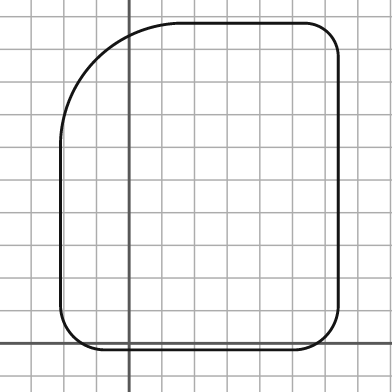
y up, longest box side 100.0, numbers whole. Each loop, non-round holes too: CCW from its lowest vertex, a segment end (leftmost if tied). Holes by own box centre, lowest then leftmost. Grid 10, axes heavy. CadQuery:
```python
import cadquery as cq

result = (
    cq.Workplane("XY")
    .moveTo(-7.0, -2.0)
    .lineTo(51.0, -2.0)
    .threePointArc((60.0, 2.0), (64.0, 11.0))
    .lineTo(64.0, 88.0)
    .threePointArc((61.0, 95.0), (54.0, 98.0))
    .lineTo(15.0, 98.0)
    .threePointArc((-10.0, 87.0), (-21.0, 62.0))
    .lineTo(-21.0, 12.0)
    .threePointArc((-17.0, 2.0), (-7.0, -2.0))
    .close()
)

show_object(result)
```